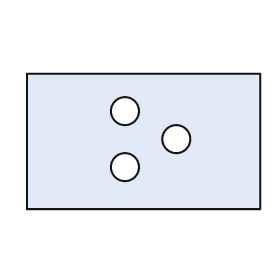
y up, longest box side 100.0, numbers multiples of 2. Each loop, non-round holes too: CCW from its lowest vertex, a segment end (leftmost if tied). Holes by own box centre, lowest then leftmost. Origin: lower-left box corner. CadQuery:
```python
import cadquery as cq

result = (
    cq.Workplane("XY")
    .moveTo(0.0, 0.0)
    .lineTo(100.0, 0.0)
    .lineTo(100.0, 58.0)
    .lineTo(0.0, 58.0)
    .close()
    .moveTo(42.0, 18.0)
    .circle(6.0)
    .moveTo(64.0, 30.0)
    .circle(6.0)
    .moveTo(42.0, 42.0)
    .circle(6.0)
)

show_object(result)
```